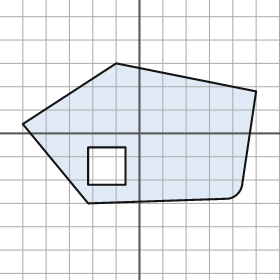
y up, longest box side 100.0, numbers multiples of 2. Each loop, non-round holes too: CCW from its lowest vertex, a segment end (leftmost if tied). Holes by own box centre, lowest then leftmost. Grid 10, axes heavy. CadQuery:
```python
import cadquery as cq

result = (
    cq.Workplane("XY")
    .moveTo(-22.0, -30.0)
    .lineTo(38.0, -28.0)
    .threePointArc((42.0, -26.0), (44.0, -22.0))
    .lineTo(50.0, 18.0)
    .lineTo(-10.0, 30.0)
    .lineTo(-50.0, 4.0)
    .close()
    .moveTo(-22.0, -22.0)
    .lineTo(-6.0, -22.0)
    .lineTo(-6.0, -6.0)
    .lineTo(-22.0, -6.0)
    .close()
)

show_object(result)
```